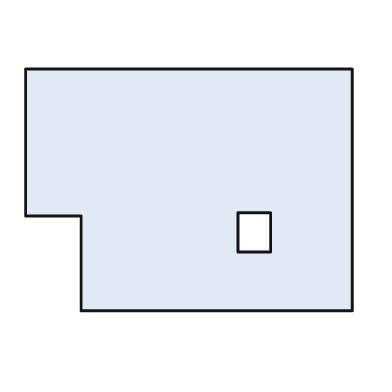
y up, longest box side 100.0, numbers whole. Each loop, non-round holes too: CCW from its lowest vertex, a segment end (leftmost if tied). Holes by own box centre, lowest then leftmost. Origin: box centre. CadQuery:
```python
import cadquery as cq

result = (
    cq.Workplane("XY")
    .moveTo(-33.0, -37.0)
    .lineTo(50.0, -37.0)
    .lineTo(50.0, 37.0)
    .lineTo(-50.0, 37.0)
    .lineTo(-50.0, -8.0)
    .lineTo(-33.0, -8.0)
    .close()
    .moveTo(15.0, -19.0)
    .lineTo(25.0, -19.0)
    .lineTo(25.0, -7.0)
    .lineTo(15.0, -7.0)
    .close()
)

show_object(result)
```